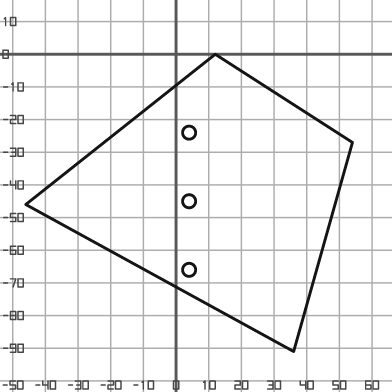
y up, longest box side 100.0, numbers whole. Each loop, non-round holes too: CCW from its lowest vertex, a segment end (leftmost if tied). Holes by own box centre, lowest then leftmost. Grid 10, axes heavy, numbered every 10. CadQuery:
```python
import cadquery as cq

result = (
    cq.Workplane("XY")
    .moveTo(36.0, -91.0)
    .lineTo(54.0, -27.0)
    .lineTo(12.0, 0.0)
    .lineTo(-46.0, -46.0)
    .close()
    .moveTo(4.0, -66.0)
    .circle(2.0)
    .moveTo(4.0, -45.0)
    .circle(2.0)
    .moveTo(4.0, -24.0)
    .circle(2.0)
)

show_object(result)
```